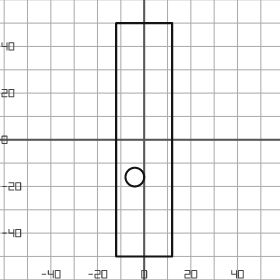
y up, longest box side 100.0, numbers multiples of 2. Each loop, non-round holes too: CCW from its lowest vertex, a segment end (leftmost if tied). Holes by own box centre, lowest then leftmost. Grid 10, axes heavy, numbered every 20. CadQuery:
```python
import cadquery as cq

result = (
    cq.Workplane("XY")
    .moveTo(-12.0, -50.0)
    .lineTo(12.0, -50.0)
    .lineTo(12.0, 50.0)
    .lineTo(-12.0, 50.0)
    .close()
    .moveTo(-4.0, -16.0)
    .circle(4.0)
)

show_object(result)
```